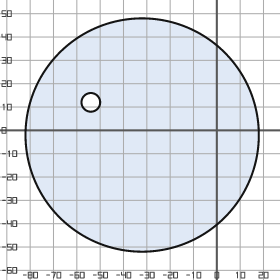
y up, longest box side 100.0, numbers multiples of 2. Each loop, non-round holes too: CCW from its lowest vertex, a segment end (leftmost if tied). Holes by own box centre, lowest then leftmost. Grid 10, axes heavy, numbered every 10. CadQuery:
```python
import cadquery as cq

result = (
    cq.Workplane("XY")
    .moveTo(-32.0, -2.0)
    .circle(50.0)
    .moveTo(-54.0, 12.0)
    .circle(4.0)
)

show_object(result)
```